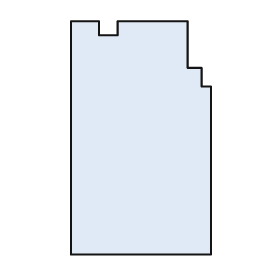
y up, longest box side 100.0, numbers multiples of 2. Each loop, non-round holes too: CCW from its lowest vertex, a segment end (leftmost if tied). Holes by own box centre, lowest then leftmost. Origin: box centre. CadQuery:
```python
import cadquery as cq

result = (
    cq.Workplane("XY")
    .moveTo(-30.0, -50.0)
    .lineTo(30.0, -50.0)
    .lineTo(30.0, 22.0)
    .lineTo(26.0, 22.0)
    .lineTo(26.0, 30.0)
    .lineTo(20.0, 30.0)
    .lineTo(20.0, 50.0)
    .lineTo(-10.0, 50.0)
    .lineTo(-10.0, 44.0)
    .lineTo(-18.0, 44.0)
    .lineTo(-18.0, 50.0)
    .lineTo(-30.0, 50.0)
    .close()
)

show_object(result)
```